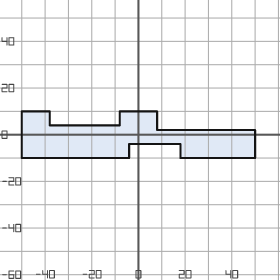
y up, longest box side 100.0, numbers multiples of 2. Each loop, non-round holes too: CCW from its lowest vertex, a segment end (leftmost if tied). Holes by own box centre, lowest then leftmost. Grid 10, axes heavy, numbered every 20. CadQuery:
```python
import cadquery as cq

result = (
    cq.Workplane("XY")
    .moveTo(-50.0, -10.0)
    .lineTo(-4.0, -10.0)
    .lineTo(-4.0, -4.0)
    .lineTo(18.0, -4.0)
    .lineTo(18.0, -10.0)
    .lineTo(50.0, -10.0)
    .lineTo(50.0, 2.0)
    .lineTo(8.0, 2.0)
    .lineTo(8.0, 10.0)
    .lineTo(-8.0, 10.0)
    .lineTo(-8.0, 4.0)
    .lineTo(-38.0, 4.0)
    .lineTo(-38.0, 10.0)
    .lineTo(-50.0, 10.0)
    .close()
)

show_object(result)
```